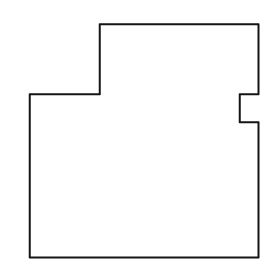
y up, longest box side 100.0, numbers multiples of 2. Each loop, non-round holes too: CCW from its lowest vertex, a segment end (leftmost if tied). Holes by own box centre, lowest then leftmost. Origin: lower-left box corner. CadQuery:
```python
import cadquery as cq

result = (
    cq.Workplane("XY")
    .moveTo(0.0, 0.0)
    .lineTo(98.0, 0.0)
    .lineTo(98.0, 58.0)
    .lineTo(90.0, 58.0)
    .lineTo(90.0, 70.0)
    .lineTo(98.0, 70.0)
    .lineTo(98.0, 100.0)
    .lineTo(30.0, 100.0)
    .lineTo(30.0, 70.0)
    .lineTo(0.0, 70.0)
    .close()
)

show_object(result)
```